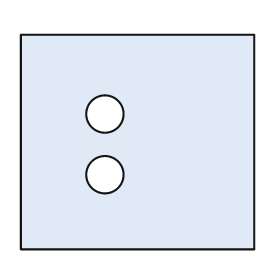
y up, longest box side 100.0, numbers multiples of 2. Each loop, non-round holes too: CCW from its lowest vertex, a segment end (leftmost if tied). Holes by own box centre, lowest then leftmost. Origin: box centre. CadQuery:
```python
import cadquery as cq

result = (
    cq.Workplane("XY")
    .moveTo(-50.0, -46.0)
    .lineTo(50.0, -46.0)
    .lineTo(50.0, 46.0)
    .lineTo(-50.0, 46.0)
    .close()
    .moveTo(-14.0, -14.0)
    .circle(8.0)
    .moveTo(-14.0, 12.0)
    .circle(8.0)
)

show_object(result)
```